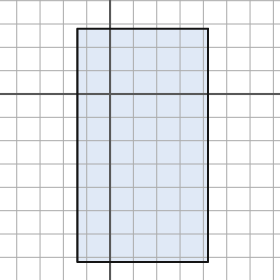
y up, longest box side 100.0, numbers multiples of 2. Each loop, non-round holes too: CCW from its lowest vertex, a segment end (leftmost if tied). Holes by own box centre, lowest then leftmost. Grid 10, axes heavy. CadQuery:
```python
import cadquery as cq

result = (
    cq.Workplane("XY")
    .moveTo(-14.0, -72.0)
    .lineTo(42.0, -72.0)
    .lineTo(42.0, 28.0)
    .lineTo(-14.0, 28.0)
    .close()
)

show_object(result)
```